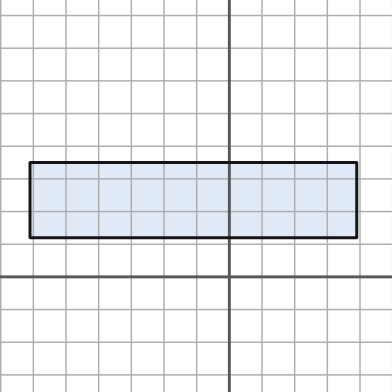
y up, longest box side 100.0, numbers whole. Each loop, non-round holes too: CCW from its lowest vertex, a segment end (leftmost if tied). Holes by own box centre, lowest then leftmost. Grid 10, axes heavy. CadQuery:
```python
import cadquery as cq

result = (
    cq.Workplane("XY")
    .moveTo(-61.0, 12.0)
    .lineTo(39.0, 12.0)
    .lineTo(39.0, 35.0)
    .lineTo(-61.0, 35.0)
    .close()
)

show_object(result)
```